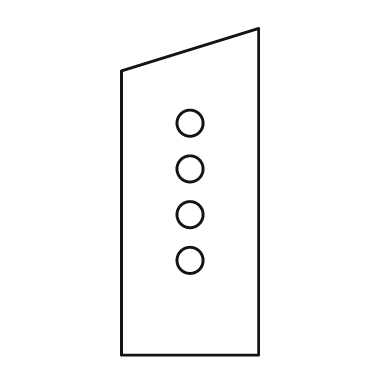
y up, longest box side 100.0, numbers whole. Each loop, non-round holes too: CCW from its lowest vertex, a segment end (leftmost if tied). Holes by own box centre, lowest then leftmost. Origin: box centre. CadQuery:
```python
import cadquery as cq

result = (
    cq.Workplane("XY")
    .moveTo(-21.0, -50.0)
    .lineTo(21.0, -50.0)
    .lineTo(21.0, 50.0)
    .lineTo(-21.0, 37.0)
    .close()
    .moveTo(0.0, -21.0)
    .circle(4.0)
    .moveTo(0.0, -7.0)
    .circle(4.0)
    .moveTo(0.0, 7.0)
    .circle(4.0)
    .moveTo(0.0, 21.0)
    .circle(4.0)
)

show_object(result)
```